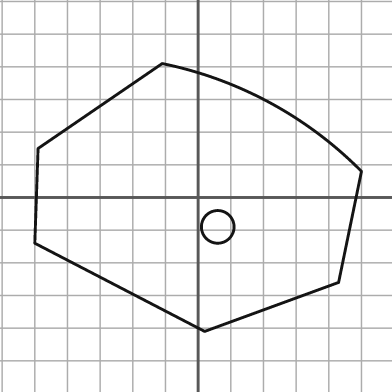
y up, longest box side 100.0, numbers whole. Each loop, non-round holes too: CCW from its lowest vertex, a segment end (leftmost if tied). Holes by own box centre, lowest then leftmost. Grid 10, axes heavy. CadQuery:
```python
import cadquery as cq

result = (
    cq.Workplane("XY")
    .moveTo(2.0, -41.0)
    .lineTo(43.0, -26.0)
    .lineTo(50.0, 8.0)
    .threePointArc((22.0, 29.0), (-11.0, 41.0))
    .lineTo(-49.0, 15.0)
    .lineTo(-50.0, -14.0)
    .close()
    .moveTo(6.0, -9.0)
    .circle(5.0)
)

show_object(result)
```